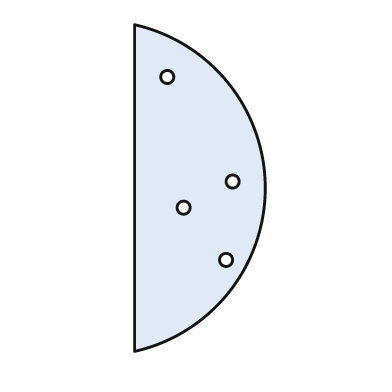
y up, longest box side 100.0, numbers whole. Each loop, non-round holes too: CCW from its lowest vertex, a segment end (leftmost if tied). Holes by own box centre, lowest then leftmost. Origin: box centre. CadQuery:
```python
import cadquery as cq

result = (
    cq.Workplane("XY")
    .moveTo(-20.0, -50.0)
    .threePointArc((20.0, 0.0), (-20.0, 50.0))
    .close()
    .moveTo(8.0, -22.0)
    .circle(2.0)
    .moveTo(-5.0, -6.0)
    .circle(2.0)
    .moveTo(10.0, 2.0)
    .circle(2.0)
    .moveTo(-10.0, 34.0)
    .circle(2.0)
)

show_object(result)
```